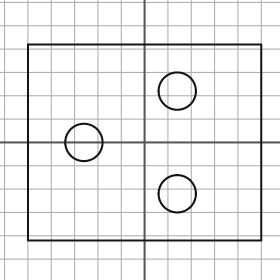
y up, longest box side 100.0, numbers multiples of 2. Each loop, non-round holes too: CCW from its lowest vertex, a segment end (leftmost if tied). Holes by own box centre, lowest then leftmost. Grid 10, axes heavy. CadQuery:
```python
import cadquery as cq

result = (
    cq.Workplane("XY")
    .moveTo(-50.0, -42.0)
    .lineTo(50.0, -42.0)
    .lineTo(50.0, 42.0)
    .lineTo(-50.0, 42.0)
    .close()
    .moveTo(14.0, -22.0)
    .circle(8.0)
    .moveTo(-26.0, 0.0)
    .circle(8.0)
    .moveTo(14.0, 22.0)
    .circle(8.0)
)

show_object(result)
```